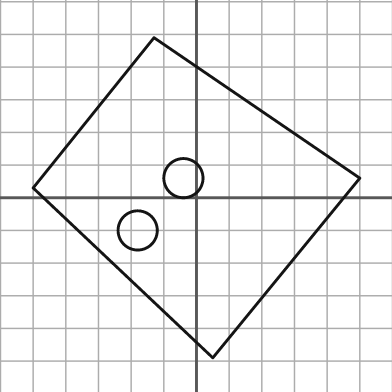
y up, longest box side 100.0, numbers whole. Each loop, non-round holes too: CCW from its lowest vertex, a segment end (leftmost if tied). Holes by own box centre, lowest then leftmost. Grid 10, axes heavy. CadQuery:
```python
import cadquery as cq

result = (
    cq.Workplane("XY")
    .moveTo(5.0, -49.0)
    .lineTo(50.0, 6.0)
    .lineTo(-13.0, 49.0)
    .lineTo(-50.0, 3.0)
    .close()
    .moveTo(-18.0, -10.0)
    .circle(6.0)
    .moveTo(-4.0, 6.0)
    .circle(6.0)
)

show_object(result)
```